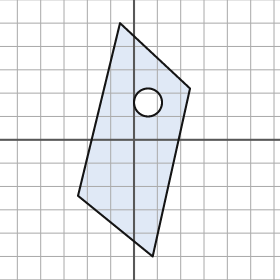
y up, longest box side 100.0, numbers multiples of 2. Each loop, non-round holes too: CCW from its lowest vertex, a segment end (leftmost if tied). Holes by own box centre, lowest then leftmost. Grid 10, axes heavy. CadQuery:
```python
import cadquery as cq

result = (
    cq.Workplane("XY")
    .moveTo(8.0, -50.0)
    .lineTo(24.0, 22.0)
    .lineTo(-6.0, 50.0)
    .lineTo(-24.0, -24.0)
    .close()
    .moveTo(6.0, 16.0)
    .circle(6.0)
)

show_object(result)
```